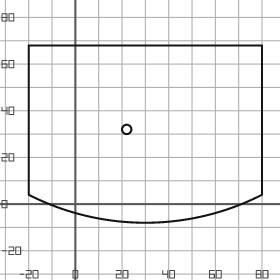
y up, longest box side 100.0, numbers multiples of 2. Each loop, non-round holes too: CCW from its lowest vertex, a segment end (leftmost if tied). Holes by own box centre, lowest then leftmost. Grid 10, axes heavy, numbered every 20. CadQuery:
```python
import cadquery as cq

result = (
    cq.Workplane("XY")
    .moveTo(-20.0, 4.0)
    .threePointArc((30.0, -8.0), (80.0, 4.0))
    .lineTo(80.0, 68.0)
    .lineTo(-20.0, 68.0)
    .close()
    .moveTo(22.0, 32.0)
    .circle(2.0)
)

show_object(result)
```